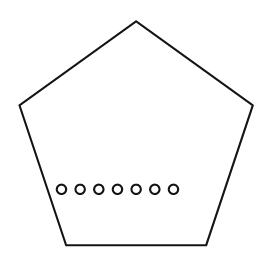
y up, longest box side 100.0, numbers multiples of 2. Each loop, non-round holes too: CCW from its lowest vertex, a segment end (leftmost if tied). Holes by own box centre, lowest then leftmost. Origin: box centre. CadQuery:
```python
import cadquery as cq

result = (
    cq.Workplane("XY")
    .moveTo(-30.0, -48.0)
    .lineTo(30.0, -48.0)
    .lineTo(50.0, 12.0)
    .lineTo(0.0, 48.0)
    .lineTo(-50.0, 12.0)
    .close()
    .moveTo(-32.0, -24.0)
    .circle(2.0)
    .moveTo(-24.0, -24.0)
    .circle(2.0)
    .moveTo(-16.0, -24.0)
    .circle(2.0)
    .moveTo(-8.0, -24.0)
    .circle(2.0)
    .moveTo(0.0, -24.0)
    .circle(2.0)
    .moveTo(8.0, -24.0)
    .circle(2.0)
    .moveTo(16.0, -24.0)
    .circle(2.0)
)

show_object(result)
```